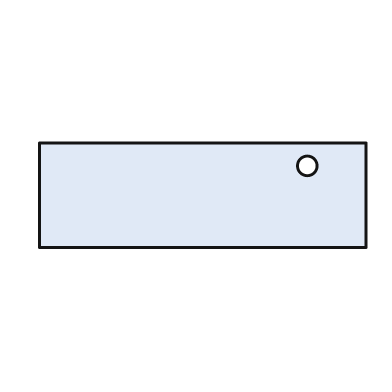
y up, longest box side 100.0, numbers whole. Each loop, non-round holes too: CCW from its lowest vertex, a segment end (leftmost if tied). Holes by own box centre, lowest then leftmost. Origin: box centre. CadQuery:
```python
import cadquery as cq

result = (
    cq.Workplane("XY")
    .moveTo(-50.0, -16.0)
    .lineTo(50.0, -16.0)
    .lineTo(50.0, 16.0)
    .lineTo(-50.0, 16.0)
    .close()
    .moveTo(32.0, 9.0)
    .circle(3.0)
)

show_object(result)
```